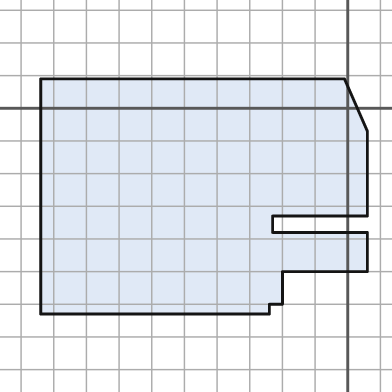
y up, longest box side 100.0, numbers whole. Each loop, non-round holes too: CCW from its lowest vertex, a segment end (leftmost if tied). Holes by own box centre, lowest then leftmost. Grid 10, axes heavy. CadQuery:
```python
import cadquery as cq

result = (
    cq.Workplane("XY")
    .moveTo(-94.0, -63.0)
    .lineTo(-24.0, -63.0)
    .lineTo(-24.0, -60.0)
    .lineTo(-20.0, -60.0)
    .lineTo(-20.0, -50.0)
    .lineTo(6.0, -50.0)
    .lineTo(6.0, -38.0)
    .lineTo(-23.0, -38.0)
    .lineTo(-23.0, -33.0)
    .lineTo(6.0, -33.0)
    .lineTo(6.0, -7.0)
    .lineTo(-1.0, 9.0)
    .lineTo(-94.0, 9.0)
    .close()
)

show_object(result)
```